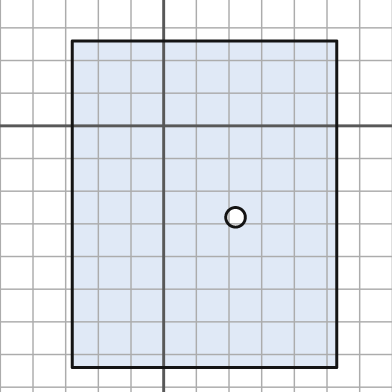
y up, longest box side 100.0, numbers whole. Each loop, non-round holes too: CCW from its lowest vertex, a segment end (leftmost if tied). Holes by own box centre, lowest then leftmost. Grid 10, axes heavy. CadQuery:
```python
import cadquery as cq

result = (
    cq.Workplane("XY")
    .moveTo(-28.0, -74.0)
    .lineTo(53.0, -74.0)
    .lineTo(53.0, 26.0)
    .lineTo(-28.0, 26.0)
    .close()
    .moveTo(22.0, -28.0)
    .circle(3.0)
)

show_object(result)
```